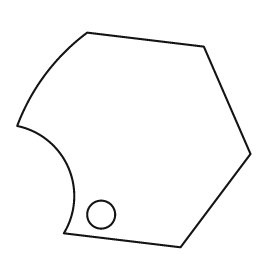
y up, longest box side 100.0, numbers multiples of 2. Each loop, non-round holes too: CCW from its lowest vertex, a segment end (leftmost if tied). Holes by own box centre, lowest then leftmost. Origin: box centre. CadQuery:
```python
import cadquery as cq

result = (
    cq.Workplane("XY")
    .moveTo(20.0, -46.0)
    .lineTo(50.0, -6.0)
    .lineTo(30.0, 40.0)
    .lineTo(-20.0, 46.0)
    .threePointArc((-38.0, 28.0), (-50.0, 6.0))
    .threePointArc((-28.0, -12.0), (-30.0, -40.0))
    .close()
    .moveTo(-14.0, -32.0)
    .circle(6.0)
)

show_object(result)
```